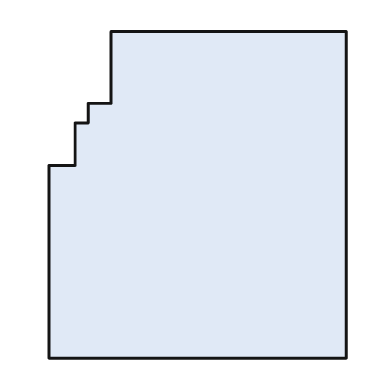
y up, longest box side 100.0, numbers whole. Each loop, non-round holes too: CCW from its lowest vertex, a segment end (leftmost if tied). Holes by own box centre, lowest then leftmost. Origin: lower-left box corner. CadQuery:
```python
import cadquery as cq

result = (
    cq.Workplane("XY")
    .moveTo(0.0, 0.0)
    .lineTo(91.0, 0.0)
    .lineTo(91.0, 100.0)
    .lineTo(19.0, 100.0)
    .lineTo(19.0, 78.0)
    .lineTo(12.0, 78.0)
    .lineTo(12.0, 72.0)
    .lineTo(8.0, 72.0)
    .lineTo(8.0, 59.0)
    .lineTo(0.0, 59.0)
    .close()
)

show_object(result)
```